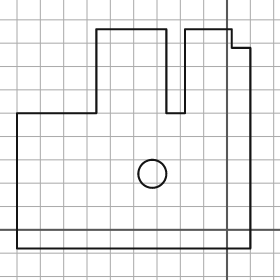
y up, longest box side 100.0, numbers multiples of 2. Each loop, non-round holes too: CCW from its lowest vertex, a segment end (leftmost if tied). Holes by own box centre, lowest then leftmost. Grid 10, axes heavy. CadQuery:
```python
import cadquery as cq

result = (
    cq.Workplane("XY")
    .moveTo(-90.0, -8.0)
    .lineTo(10.0, -8.0)
    .lineTo(10.0, 78.0)
    .lineTo(2.0, 78.0)
    .lineTo(2.0, 86.0)
    .lineTo(-18.0, 86.0)
    .lineTo(-18.0, 50.0)
    .lineTo(-26.0, 50.0)
    .lineTo(-26.0, 86.0)
    .lineTo(-56.0, 86.0)
    .lineTo(-56.0, 50.0)
    .lineTo(-90.0, 50.0)
    .close()
    .moveTo(-32.0, 24.0)
    .circle(6.0)
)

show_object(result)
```